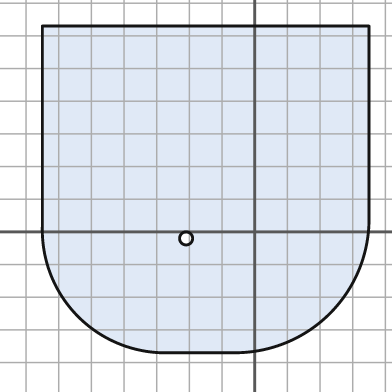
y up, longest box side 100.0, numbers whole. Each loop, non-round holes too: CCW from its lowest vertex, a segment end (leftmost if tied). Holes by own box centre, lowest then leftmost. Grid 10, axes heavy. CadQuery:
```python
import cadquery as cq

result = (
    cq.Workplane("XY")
    .moveTo(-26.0, -37.0)
    .lineTo(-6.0, -37.0)
    .threePointArc((23.0, -25.0), (35.0, 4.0))
    .lineTo(35.0, 63.0)
    .lineTo(-65.0, 63.0)
    .lineTo(-65.0, 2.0)
    .threePointArc((-54.0, -26.0), (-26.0, -37.0))
    .close()
    .moveTo(-21.0, -2.0)
    .circle(2.0)
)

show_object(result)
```